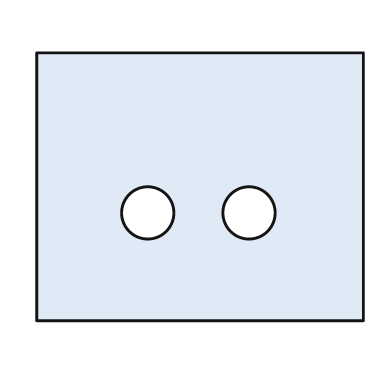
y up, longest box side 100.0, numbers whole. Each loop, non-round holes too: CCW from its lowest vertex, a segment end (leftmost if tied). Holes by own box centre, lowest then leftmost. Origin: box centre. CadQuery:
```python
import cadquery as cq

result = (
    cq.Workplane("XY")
    .moveTo(-50.0, -41.0)
    .lineTo(50.0, -41.0)
    .lineTo(50.0, 41.0)
    .lineTo(-50.0, 41.0)
    .close()
    .moveTo(-16.0, -8.0)
    .circle(8.0)
    .moveTo(15.0, -8.0)
    .circle(8.0)
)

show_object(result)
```